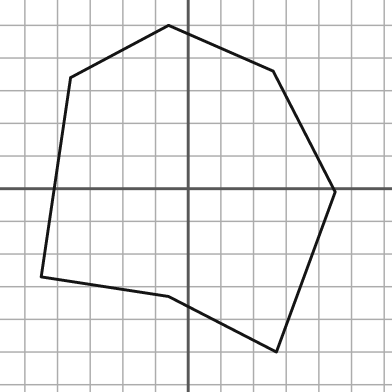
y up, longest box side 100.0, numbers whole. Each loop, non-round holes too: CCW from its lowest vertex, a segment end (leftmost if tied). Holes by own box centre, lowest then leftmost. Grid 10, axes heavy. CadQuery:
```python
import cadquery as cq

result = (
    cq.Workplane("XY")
    .moveTo(27.0, -50.0)
    .lineTo(45.0, -1.0)
    .lineTo(26.0, 36.0)
    .lineTo(-6.0, 50.0)
    .lineTo(-36.0, 34.0)
    .lineTo(-45.0, -27.0)
    .lineTo(-6.0, -33.0)
    .close()
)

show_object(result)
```